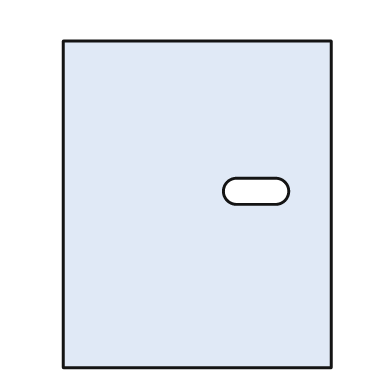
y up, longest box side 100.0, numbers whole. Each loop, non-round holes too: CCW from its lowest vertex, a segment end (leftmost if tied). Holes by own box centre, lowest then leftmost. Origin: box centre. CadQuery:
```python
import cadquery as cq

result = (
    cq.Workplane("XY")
    .moveTo(-41.0, -50.0)
    .lineTo(41.0, -50.0)
    .lineTo(41.0, 50.0)
    .lineTo(-41.0, 50.0)
    .close()
    .moveTo(12.0, 0.0)
    .lineTo(24.0, 0.0)
    .threePointArc((28.0, 4.0), (24.0, 8.0))
    .lineTo(12.0, 8.0)
    .threePointArc((8.0, 4.0), (12.0, 0.0))
    .close()
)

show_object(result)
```